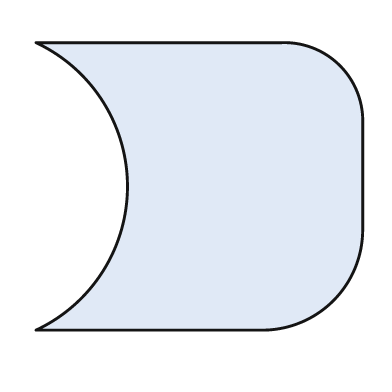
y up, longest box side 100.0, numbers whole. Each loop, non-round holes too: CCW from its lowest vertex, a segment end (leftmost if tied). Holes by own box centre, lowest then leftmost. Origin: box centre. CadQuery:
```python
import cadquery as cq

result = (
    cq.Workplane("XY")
    .moveTo(-50.0, -44.0)
    .lineTo(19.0, -44.0)
    .threePointArc((41.0, -35.0), (50.0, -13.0))
    .lineTo(50.0, 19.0)
    .threePointArc((43.0, 37.0), (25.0, 44.0))
    .lineTo(-50.0, 44.0)
    .threePointArc((-22.0, 0.0), (-50.0, -44.0))
    .close()
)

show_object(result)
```